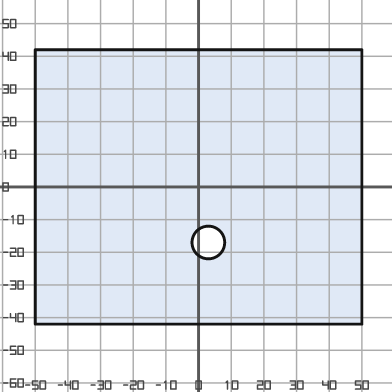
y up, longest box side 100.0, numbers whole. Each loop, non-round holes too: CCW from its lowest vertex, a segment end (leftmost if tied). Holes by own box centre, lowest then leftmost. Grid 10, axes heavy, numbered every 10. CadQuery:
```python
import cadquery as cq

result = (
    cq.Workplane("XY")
    .moveTo(-50.0, -42.0)
    .lineTo(50.0, -42.0)
    .lineTo(50.0, 42.0)
    .lineTo(-50.0, 42.0)
    .close()
    .moveTo(3.0, -17.0)
    .circle(5.0)
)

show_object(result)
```